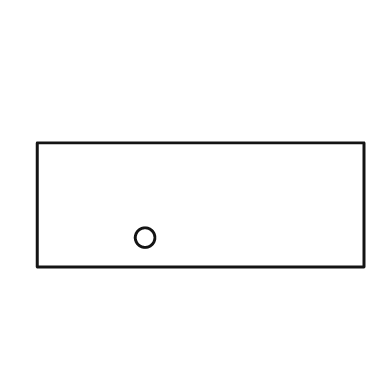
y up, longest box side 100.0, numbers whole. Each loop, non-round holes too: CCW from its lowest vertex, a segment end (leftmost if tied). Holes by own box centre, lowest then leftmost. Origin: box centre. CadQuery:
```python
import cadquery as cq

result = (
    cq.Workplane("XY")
    .moveTo(-50.0, -19.0)
    .lineTo(50.0, -19.0)
    .lineTo(50.0, 19.0)
    .lineTo(-50.0, 19.0)
    .close()
    .moveTo(-17.0, -10.0)
    .circle(3.0)
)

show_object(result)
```